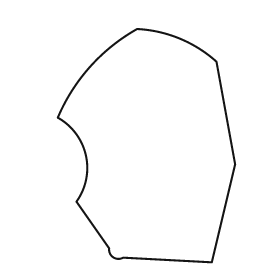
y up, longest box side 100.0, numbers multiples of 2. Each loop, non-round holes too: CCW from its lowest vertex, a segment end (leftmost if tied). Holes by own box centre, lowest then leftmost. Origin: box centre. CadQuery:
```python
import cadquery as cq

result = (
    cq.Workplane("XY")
    .moveTo(28.0, -50.0)
    .lineTo(38.0, -8.0)
    .lineTo(30.0, 36.0)
    .threePointArc((14.0, 46.0), (-4.0, 50.0))
    .threePointArc((-24.0, 34.0), (-38.0, 12.0))
    .threePointArc((-26.0, -4.0), (-30.0, -24.0))
    .lineTo(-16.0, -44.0)
    .threePointArc((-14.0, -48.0), (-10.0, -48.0))
    .close()
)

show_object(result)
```